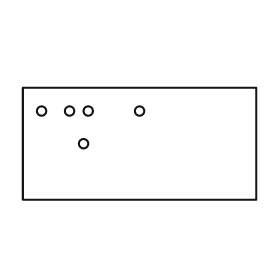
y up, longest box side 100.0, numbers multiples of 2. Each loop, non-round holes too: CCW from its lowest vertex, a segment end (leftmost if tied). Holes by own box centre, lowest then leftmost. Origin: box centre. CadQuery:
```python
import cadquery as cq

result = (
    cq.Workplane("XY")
    .moveTo(-50.0, -24.0)
    .lineTo(50.0, -24.0)
    .lineTo(50.0, 24.0)
    .lineTo(-50.0, 24.0)
    .close()
    .moveTo(-24.0, 0.0)
    .circle(2.0)
    .moveTo(-42.0, 14.0)
    .circle(2.0)
    .moveTo(-30.0, 14.0)
    .circle(2.0)
    .moveTo(-22.0, 14.0)
    .circle(2.0)
    .moveTo(0.0, 14.0)
    .circle(2.0)
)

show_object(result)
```